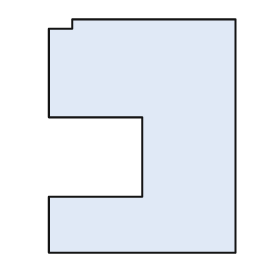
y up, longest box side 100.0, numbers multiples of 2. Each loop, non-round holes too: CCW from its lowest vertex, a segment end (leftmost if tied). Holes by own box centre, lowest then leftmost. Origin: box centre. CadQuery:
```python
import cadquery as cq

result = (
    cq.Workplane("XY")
    .moveTo(-40.0, -50.0)
    .lineTo(40.0, -50.0)
    .lineTo(40.0, 50.0)
    .lineTo(-30.0, 50.0)
    .lineTo(-30.0, 46.0)
    .lineTo(-40.0, 46.0)
    .lineTo(-40.0, 8.0)
    .lineTo(0.0, 8.0)
    .lineTo(0.0, -26.0)
    .lineTo(-40.0, -26.0)
    .close()
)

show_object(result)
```